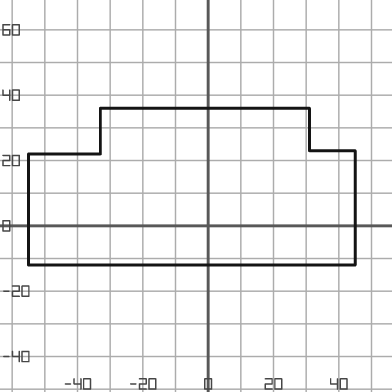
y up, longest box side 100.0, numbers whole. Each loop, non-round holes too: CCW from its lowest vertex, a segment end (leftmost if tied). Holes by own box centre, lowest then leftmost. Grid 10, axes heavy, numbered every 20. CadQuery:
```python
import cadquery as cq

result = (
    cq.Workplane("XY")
    .moveTo(-55.0, -12.0)
    .lineTo(45.0, -12.0)
    .lineTo(45.0, 23.0)
    .lineTo(31.0, 23.0)
    .lineTo(31.0, 36.0)
    .lineTo(-33.0, 36.0)
    .lineTo(-33.0, 22.0)
    .lineTo(-55.0, 22.0)
    .close()
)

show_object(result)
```